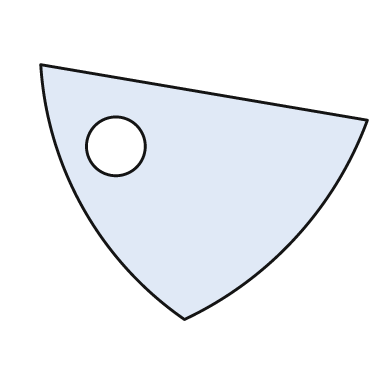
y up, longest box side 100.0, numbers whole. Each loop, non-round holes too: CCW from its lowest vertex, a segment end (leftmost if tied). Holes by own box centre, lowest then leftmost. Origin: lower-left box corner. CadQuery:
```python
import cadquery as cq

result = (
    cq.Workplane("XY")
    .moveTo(44.0, 0.0)
    .threePointArc((78.0, 25.0), (100.0, 61.0))
    .lineTo(0.0, 78.0)
    .threePointArc((13.0, 34.0), (44.0, 0.0))
    .close()
    .moveTo(23.0, 53.0)
    .circle(9.0)
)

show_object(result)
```